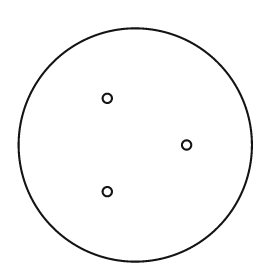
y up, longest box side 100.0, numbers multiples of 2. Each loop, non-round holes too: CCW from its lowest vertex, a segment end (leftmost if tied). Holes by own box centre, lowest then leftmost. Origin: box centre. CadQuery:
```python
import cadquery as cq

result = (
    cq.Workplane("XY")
    .moveTo(0.0, 0.0)
    .circle(50.0)
    .moveTo(-12.0, -20.0)
    .circle(2.0)
    .moveTo(22.0, 0.0)
    .circle(2.0)
    .moveTo(-12.0, 20.0)
    .circle(2.0)
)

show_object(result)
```